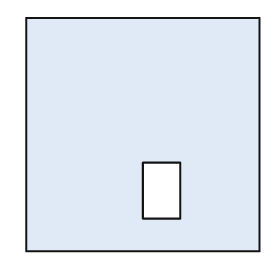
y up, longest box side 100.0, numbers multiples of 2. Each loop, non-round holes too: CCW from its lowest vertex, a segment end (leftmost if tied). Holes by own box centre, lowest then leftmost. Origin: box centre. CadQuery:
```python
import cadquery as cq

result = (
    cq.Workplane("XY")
    .moveTo(-50.0, -50.0)
    .lineTo(50.0, -50.0)
    .lineTo(50.0, 50.0)
    .lineTo(-50.0, 50.0)
    .close()
    .moveTo(0.0, -36.0)
    .lineTo(16.0, -36.0)
    .lineTo(16.0, -12.0)
    .lineTo(0.0, -12.0)
    .close()
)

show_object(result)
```